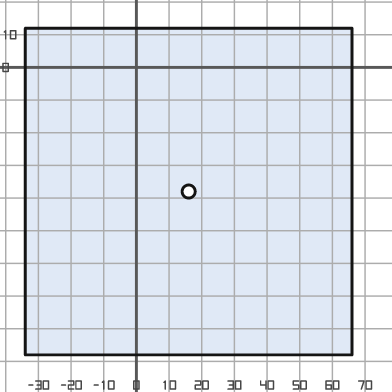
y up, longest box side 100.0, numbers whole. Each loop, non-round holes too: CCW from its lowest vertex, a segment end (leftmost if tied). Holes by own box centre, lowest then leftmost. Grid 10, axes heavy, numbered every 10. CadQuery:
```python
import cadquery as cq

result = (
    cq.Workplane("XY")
    .moveTo(-34.0, -88.0)
    .lineTo(66.0, -88.0)
    .lineTo(66.0, 12.0)
    .lineTo(-34.0, 12.0)
    .close()
    .moveTo(16.0, -38.0)
    .circle(2.0)
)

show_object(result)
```